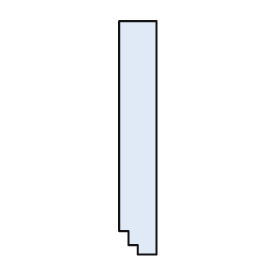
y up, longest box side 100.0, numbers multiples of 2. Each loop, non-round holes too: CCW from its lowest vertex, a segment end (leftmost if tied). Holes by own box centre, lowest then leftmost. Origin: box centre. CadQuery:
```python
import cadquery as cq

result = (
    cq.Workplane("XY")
    .moveTo(0.0, -50.0)
    .lineTo(8.0, -50.0)
    .lineTo(8.0, 50.0)
    .lineTo(-8.0, 50.0)
    .lineTo(-8.0, -40.0)
    .lineTo(-4.0, -40.0)
    .lineTo(-4.0, -46.0)
    .lineTo(0.0, -46.0)
    .close()
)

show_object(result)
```